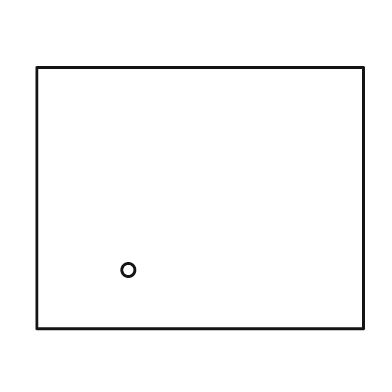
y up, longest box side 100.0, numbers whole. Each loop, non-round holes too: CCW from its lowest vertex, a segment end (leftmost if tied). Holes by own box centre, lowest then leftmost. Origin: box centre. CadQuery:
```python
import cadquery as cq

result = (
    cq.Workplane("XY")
    .moveTo(-50.0, -40.0)
    .lineTo(50.0, -40.0)
    .lineTo(50.0, 40.0)
    .lineTo(-50.0, 40.0)
    .close()
    .moveTo(-22.0, -22.0)
    .circle(2.0)
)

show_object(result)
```